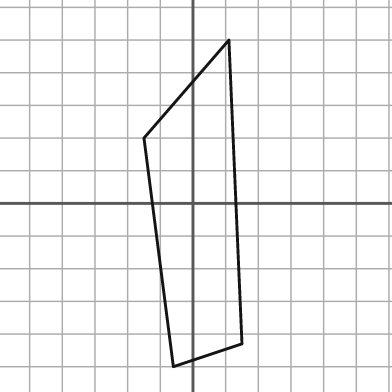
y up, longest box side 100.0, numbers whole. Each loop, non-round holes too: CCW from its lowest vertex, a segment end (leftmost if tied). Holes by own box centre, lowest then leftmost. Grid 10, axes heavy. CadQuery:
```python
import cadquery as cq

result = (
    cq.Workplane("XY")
    .moveTo(-6.0, -50.0)
    .lineTo(15.0, -43.0)
    .lineTo(11.0, 50.0)
    .lineTo(-15.0, 20.0)
    .close()
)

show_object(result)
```